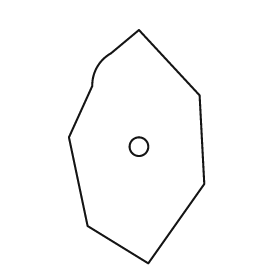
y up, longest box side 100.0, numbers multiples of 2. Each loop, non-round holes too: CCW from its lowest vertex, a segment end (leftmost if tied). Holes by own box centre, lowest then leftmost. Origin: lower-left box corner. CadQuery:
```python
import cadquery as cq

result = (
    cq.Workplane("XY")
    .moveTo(34.0, 0.0)
    .lineTo(58.0, 34.0)
    .lineTo(56.0, 72.0)
    .lineTo(30.0, 100.0)
    .lineTo(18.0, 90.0)
    .threePointArc((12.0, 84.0), (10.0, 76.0))
    .lineTo(0.0, 54.0)
    .lineTo(8.0, 16.0)
    .close()
    .moveTo(30.0, 50.0)
    .circle(4.0)
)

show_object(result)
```